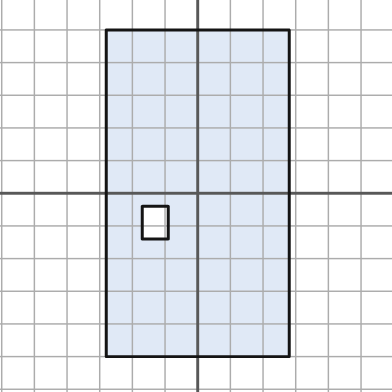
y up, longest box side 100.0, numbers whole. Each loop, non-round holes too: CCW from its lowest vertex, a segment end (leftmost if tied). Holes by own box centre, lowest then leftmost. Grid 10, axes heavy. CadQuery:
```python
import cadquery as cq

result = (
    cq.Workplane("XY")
    .moveTo(-28.0, -50.0)
    .lineTo(28.0, -50.0)
    .lineTo(28.0, 50.0)
    .lineTo(-28.0, 50.0)
    .close()
    .moveTo(-17.0, -14.0)
    .lineTo(-9.0, -14.0)
    .lineTo(-9.0, -4.0)
    .lineTo(-17.0, -4.0)
    .close()
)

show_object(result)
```